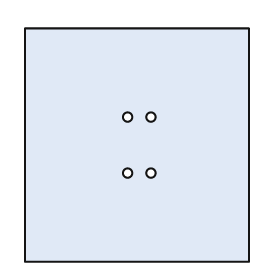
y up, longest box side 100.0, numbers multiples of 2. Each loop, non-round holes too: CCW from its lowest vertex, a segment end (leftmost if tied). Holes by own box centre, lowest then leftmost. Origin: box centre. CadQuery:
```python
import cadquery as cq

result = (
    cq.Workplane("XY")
    .moveTo(-48.0, -50.0)
    .lineTo(48.0, -50.0)
    .lineTo(48.0, 50.0)
    .lineTo(-48.0, 50.0)
    .close()
    .moveTo(-4.0, -12.0)
    .circle(2.0)
    .moveTo(6.0, -12.0)
    .circle(2.0)
    .moveTo(-4.0, 12.0)
    .circle(2.0)
    .moveTo(6.0, 12.0)
    .circle(2.0)
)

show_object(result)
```